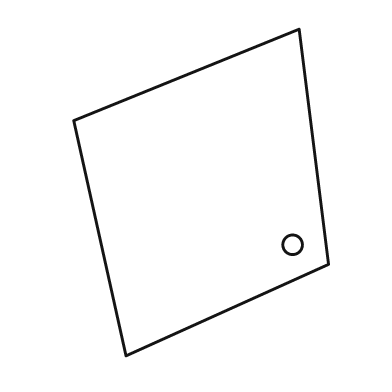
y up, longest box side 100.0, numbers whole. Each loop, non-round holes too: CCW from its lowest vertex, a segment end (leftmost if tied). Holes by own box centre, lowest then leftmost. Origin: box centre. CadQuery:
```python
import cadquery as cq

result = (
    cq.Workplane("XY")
    .moveTo(-23.0, -50.0)
    .lineTo(39.0, -22.0)
    .lineTo(30.0, 50.0)
    .lineTo(-39.0, 22.0)
    .close()
    .moveTo(28.0, -16.0)
    .circle(3.0)
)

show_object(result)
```